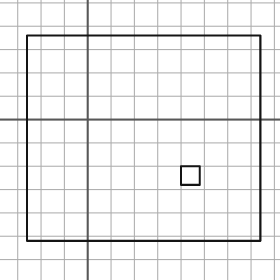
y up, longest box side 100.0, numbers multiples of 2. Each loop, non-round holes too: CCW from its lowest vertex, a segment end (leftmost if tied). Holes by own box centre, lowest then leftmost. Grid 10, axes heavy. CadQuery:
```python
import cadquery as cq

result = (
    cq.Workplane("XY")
    .moveTo(-26.0, -52.0)
    .lineTo(74.0, -52.0)
    .lineTo(74.0, 36.0)
    .lineTo(-26.0, 36.0)
    .close()
    .moveTo(40.0, -28.0)
    .lineTo(48.0, -28.0)
    .lineTo(48.0, -20.0)
    .lineTo(40.0, -20.0)
    .close()
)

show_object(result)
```